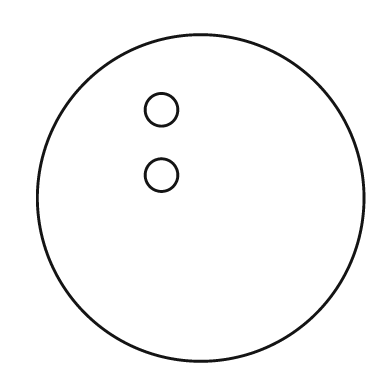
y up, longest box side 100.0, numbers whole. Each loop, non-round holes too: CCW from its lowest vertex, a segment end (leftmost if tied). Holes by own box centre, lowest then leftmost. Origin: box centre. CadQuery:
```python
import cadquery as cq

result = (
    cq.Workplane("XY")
    .moveTo(0.0, 0.0)
    .circle(50.0)
    .moveTo(-12.0, 7.0)
    .circle(5.0)
    .moveTo(-12.0, 27.0)
    .circle(5.0)
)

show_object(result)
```